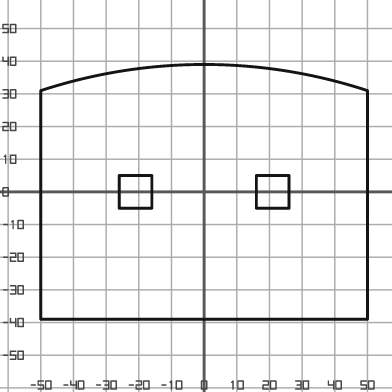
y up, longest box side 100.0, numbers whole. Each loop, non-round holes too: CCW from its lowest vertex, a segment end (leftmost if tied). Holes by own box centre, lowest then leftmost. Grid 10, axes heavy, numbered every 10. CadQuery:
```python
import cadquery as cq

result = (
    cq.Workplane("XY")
    .moveTo(-50.0, -39.0)
    .lineTo(50.0, -39.0)
    .lineTo(50.0, 31.0)
    .threePointArc((0.0, 39.0), (-50.0, 31.0))
    .close()
    .moveTo(-26.0, -5.0)
    .lineTo(-16.0, -5.0)
    .lineTo(-16.0, 5.0)
    .lineTo(-26.0, 5.0)
    .close()
    .moveTo(16.0, -5.0)
    .lineTo(26.0, -5.0)
    .lineTo(26.0, 5.0)
    .lineTo(16.0, 5.0)
    .close()
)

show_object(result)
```